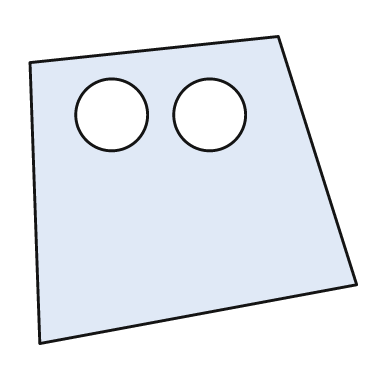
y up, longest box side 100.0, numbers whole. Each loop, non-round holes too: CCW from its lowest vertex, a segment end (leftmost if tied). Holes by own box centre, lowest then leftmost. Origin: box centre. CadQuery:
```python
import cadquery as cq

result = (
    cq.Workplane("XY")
    .moveTo(-47.0, -47.0)
    .lineTo(50.0, -29.0)
    .lineTo(26.0, 47.0)
    .lineTo(-50.0, 39.0)
    .close()
    .moveTo(-25.0, 23.0)
    .circle(11.0)
    .moveTo(5.0, 23.0)
    .circle(11.0)
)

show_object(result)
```